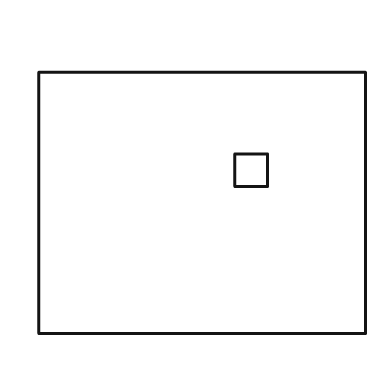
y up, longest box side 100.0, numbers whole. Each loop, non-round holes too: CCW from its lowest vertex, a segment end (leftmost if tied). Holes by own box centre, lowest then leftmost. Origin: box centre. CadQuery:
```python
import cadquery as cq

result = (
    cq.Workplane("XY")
    .moveTo(-50.0, -40.0)
    .lineTo(50.0, -40.0)
    .lineTo(50.0, 40.0)
    .lineTo(-50.0, 40.0)
    .close()
    .moveTo(10.0, 5.0)
    .lineTo(20.0, 5.0)
    .lineTo(20.0, 15.0)
    .lineTo(10.0, 15.0)
    .close()
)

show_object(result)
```